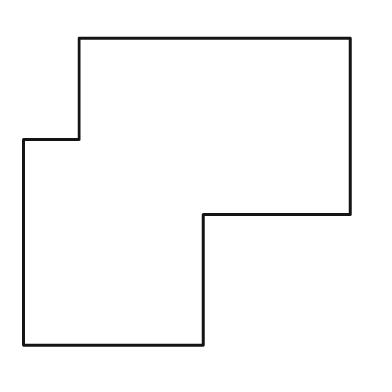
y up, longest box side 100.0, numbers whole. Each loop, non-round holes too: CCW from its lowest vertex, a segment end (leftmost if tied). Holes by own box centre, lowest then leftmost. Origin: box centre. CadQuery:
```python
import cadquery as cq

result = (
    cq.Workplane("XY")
    .moveTo(-50.0, -47.0)
    .lineTo(5.0, -47.0)
    .lineTo(5.0, -7.0)
    .lineTo(50.0, -7.0)
    .lineTo(50.0, 47.0)
    .lineTo(-33.0, 47.0)
    .lineTo(-33.0, 16.0)
    .lineTo(-50.0, 16.0)
    .close()
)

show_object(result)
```